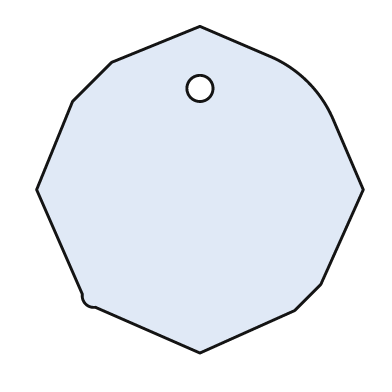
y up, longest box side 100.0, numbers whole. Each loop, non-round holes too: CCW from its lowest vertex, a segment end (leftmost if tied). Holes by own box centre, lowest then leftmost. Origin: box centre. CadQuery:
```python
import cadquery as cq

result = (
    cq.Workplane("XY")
    .moveTo(0.0, -50.0)
    .lineTo(29.0, -37.0)
    .lineTo(37.0, -29.0)
    .lineTo(50.0, 0.0)
    .lineTo(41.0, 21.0)
    .threePointArc((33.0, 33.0), (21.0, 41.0))
    .lineTo(0.0, 50.0)
    .lineTo(-27.0, 39.0)
    .lineTo(-39.0, 27.0)
    .lineTo(-50.0, 0.0)
    .lineTo(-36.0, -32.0)
    .threePointArc((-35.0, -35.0), (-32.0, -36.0))
    .close()
    .moveTo(0.0, 31.0)
    .circle(4.0)
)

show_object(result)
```